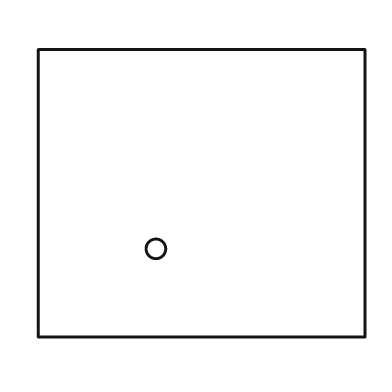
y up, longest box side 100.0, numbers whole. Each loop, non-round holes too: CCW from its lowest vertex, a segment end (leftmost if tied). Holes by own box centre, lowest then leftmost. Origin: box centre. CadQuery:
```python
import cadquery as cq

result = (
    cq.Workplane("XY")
    .moveTo(-50.0, -44.0)
    .lineTo(50.0, -44.0)
    .lineTo(50.0, 44.0)
    .lineTo(-50.0, 44.0)
    .close()
    .moveTo(-14.0, -17.0)
    .circle(3.0)
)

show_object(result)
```